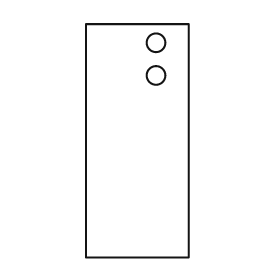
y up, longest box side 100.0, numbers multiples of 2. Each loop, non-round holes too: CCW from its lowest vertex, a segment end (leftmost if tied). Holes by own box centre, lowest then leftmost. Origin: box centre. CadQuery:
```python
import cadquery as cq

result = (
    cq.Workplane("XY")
    .moveTo(-22.0, -50.0)
    .lineTo(22.0, -50.0)
    .lineTo(22.0, 50.0)
    .lineTo(-22.0, 50.0)
    .close()
    .moveTo(8.0, 28.0)
    .circle(4.0)
    .moveTo(8.0, 42.0)
    .circle(4.0)
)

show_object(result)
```